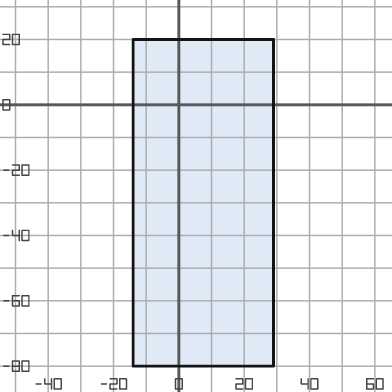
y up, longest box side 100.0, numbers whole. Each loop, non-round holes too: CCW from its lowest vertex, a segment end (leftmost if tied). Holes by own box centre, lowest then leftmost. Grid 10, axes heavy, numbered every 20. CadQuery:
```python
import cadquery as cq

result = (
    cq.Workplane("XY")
    .moveTo(-14.0, -80.0)
    .lineTo(29.0, -80.0)
    .lineTo(29.0, 20.0)
    .lineTo(-14.0, 20.0)
    .close()
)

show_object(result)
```